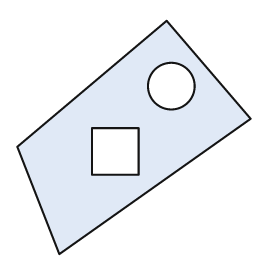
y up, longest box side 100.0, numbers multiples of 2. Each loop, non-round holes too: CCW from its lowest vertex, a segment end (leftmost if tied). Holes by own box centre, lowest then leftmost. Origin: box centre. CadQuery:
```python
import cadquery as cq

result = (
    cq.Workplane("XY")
    .moveTo(-32.0, -50.0)
    .lineTo(50.0, 8.0)
    .lineTo(14.0, 50.0)
    .lineTo(-50.0, -4.0)
    .close()
    .moveTo(-18.0, -16.0)
    .lineTo(2.0, -16.0)
    .lineTo(2.0, 4.0)
    .lineTo(-18.0, 4.0)
    .close()
    .moveTo(16.0, 22.0)
    .circle(10.0)
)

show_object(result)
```